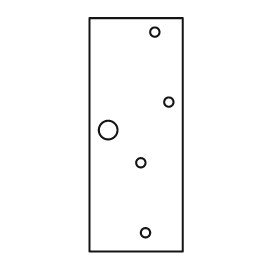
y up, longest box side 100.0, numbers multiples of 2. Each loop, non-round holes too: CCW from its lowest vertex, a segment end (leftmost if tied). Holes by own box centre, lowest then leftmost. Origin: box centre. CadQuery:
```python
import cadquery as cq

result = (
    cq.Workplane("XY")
    .moveTo(-20.0, -50.0)
    .lineTo(20.0, -50.0)
    .lineTo(20.0, 50.0)
    .lineTo(-20.0, 50.0)
    .close()
    .moveTo(4.0, -42.0)
    .circle(2.0)
    .moveTo(2.0, -12.0)
    .circle(2.0)
    .moveTo(-12.0, 2.0)
    .circle(4.0)
    .moveTo(14.0, 14.0)
    .circle(2.0)
    .moveTo(8.0, 44.0)
    .circle(2.0)
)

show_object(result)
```